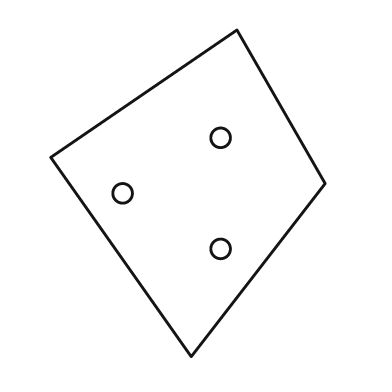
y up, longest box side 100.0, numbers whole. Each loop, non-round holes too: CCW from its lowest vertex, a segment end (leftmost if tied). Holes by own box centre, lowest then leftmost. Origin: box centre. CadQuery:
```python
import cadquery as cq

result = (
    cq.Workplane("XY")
    .moveTo(1.0, -50.0)
    .lineTo(42.0, 3.0)
    .lineTo(15.0, 50.0)
    .lineTo(-42.0, 11.0)
    .close()
    .moveTo(10.0, -17.0)
    .circle(3.0)
    .moveTo(-20.0, 0.0)
    .circle(3.0)
    .moveTo(10.0, 17.0)
    .circle(3.0)
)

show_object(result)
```